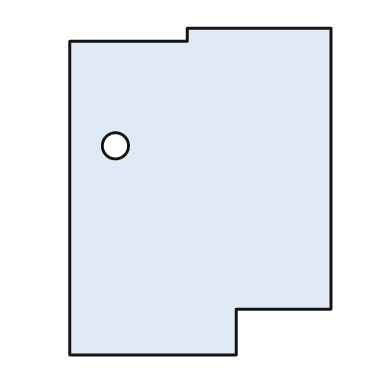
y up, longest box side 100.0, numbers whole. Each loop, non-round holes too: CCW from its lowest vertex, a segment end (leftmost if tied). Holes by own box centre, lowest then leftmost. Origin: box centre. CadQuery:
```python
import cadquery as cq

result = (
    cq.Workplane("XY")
    .moveTo(-40.0, -50.0)
    .lineTo(11.0, -50.0)
    .lineTo(11.0, -36.0)
    .lineTo(40.0, -36.0)
    .lineTo(40.0, 50.0)
    .lineTo(-4.0, 50.0)
    .lineTo(-4.0, 46.0)
    .lineTo(-40.0, 46.0)
    .close()
    .moveTo(-26.0, 14.0)
    .circle(4.0)
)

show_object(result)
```